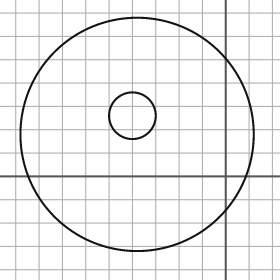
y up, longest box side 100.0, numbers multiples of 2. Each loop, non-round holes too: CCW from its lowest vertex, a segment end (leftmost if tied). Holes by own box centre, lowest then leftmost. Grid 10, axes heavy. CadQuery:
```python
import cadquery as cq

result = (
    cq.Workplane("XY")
    .moveTo(-38.0, 18.0)
    .circle(50.0)
    .moveTo(-40.0, 26.0)
    .circle(10.0)
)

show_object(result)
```